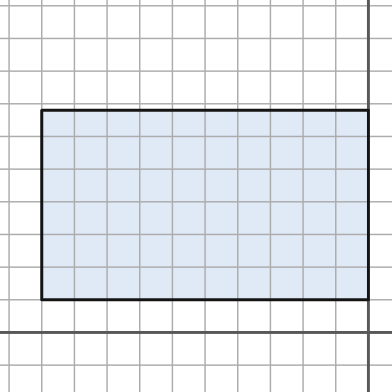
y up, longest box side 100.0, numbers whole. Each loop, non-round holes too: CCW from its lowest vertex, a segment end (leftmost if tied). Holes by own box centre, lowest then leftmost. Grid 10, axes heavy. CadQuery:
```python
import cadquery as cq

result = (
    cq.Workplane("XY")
    .moveTo(-100.0, 10.0)
    .lineTo(0.0, 10.0)
    .lineTo(0.0, 68.0)
    .lineTo(-100.0, 68.0)
    .close()
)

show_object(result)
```